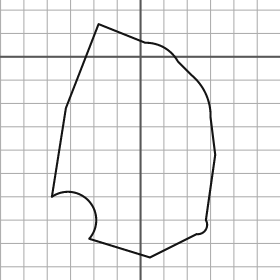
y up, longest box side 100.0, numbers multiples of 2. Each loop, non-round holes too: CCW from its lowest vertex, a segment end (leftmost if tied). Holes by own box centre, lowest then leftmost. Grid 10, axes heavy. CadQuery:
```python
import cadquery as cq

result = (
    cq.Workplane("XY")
    .moveTo(4.0, -86.0)
    .lineTo(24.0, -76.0)
    .threePointArc((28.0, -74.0), (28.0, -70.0))
    .lineTo(32.0, -42.0)
    .lineTo(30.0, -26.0)
    .threePointArc((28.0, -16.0), (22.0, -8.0))
    .lineTo(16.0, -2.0)
    .threePointArc((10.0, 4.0), (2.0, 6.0))
    .lineTo(-18.0, 14.0)
    .lineTo(-32.0, -22.0)
    .lineTo(-38.0, -60.0)
    .threePointArc((-22.0, -62.0), (-22.0, -78.0))
    .close()
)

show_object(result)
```